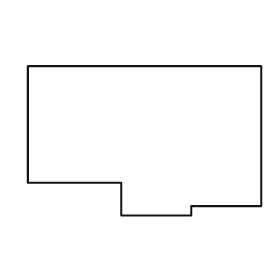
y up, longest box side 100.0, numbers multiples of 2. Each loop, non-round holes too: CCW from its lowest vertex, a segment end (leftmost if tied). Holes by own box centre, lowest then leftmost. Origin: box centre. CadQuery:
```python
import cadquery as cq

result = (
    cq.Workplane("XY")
    .moveTo(-10.0, -32.0)
    .lineTo(20.0, -32.0)
    .lineTo(20.0, -28.0)
    .lineTo(50.0, -28.0)
    .lineTo(50.0, 32.0)
    .lineTo(-50.0, 32.0)
    .lineTo(-50.0, -18.0)
    .lineTo(-10.0, -18.0)
    .close()
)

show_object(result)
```